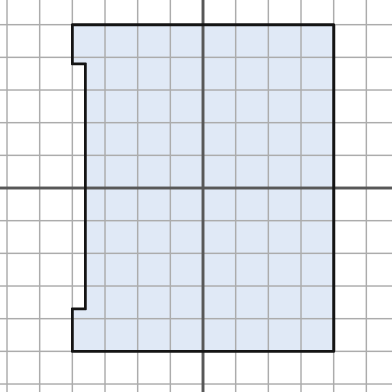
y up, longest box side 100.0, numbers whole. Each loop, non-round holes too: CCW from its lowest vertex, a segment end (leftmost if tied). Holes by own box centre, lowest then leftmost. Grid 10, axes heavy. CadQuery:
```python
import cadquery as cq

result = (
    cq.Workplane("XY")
    .moveTo(-40.0, -50.0)
    .lineTo(40.0, -50.0)
    .lineTo(40.0, 50.0)
    .lineTo(-40.0, 50.0)
    .lineTo(-40.0, 38.0)
    .lineTo(-36.0, 38.0)
    .lineTo(-36.0, -37.0)
    .lineTo(-40.0, -37.0)
    .close()
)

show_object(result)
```